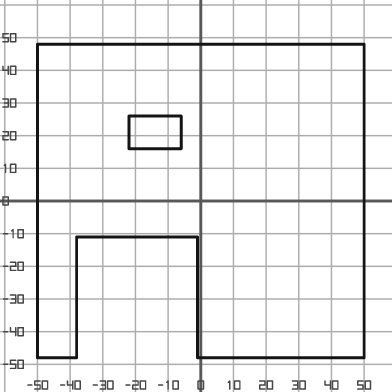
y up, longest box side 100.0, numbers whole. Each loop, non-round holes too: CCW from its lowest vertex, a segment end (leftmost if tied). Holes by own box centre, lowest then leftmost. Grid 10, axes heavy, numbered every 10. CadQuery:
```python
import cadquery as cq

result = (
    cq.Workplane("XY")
    .moveTo(-50.0, -48.0)
    .lineTo(-38.0, -48.0)
    .lineTo(-38.0, -11.0)
    .lineTo(-1.0, -11.0)
    .lineTo(-1.0, -48.0)
    .lineTo(50.0, -48.0)
    .lineTo(50.0, 48.0)
    .lineTo(-50.0, 48.0)
    .close()
    .moveTo(-22.0, 16.0)
    .lineTo(-6.0, 16.0)
    .lineTo(-6.0, 26.0)
    .lineTo(-22.0, 26.0)
    .close()
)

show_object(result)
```